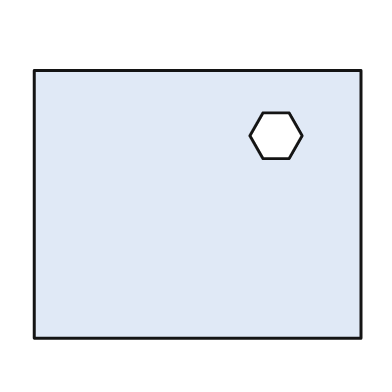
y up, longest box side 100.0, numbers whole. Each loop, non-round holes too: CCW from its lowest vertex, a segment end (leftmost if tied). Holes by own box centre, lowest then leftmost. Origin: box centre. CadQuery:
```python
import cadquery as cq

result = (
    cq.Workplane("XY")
    .moveTo(-50.0, -41.0)
    .lineTo(50.0, -41.0)
    .lineTo(50.0, 41.0)
    .lineTo(-50.0, 41.0)
    .close()
    .moveTo(20.0, 14.0)
    .lineTo(28.0, 14.0)
    .lineTo(32.0, 21.0)
    .lineTo(28.0, 28.0)
    .lineTo(20.0, 28.0)
    .lineTo(16.0, 21.0)
    .close()
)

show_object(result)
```